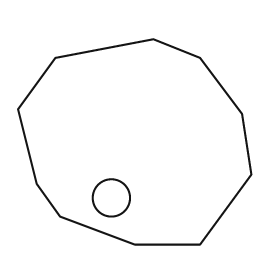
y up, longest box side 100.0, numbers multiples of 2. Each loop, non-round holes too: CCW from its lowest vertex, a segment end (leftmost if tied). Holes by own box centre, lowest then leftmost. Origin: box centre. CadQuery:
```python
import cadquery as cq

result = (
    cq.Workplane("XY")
    .moveTo(0.0, -44.0)
    .lineTo(28.0, -44.0)
    .lineTo(50.0, -14.0)
    .lineTo(46.0, 12.0)
    .lineTo(28.0, 36.0)
    .lineTo(8.0, 44.0)
    .lineTo(-34.0, 36.0)
    .lineTo(-50.0, 14.0)
    .lineTo(-42.0, -18.0)
    .lineTo(-32.0, -32.0)
    .close()
    .moveTo(-10.0, -24.0)
    .circle(8.0)
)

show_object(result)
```